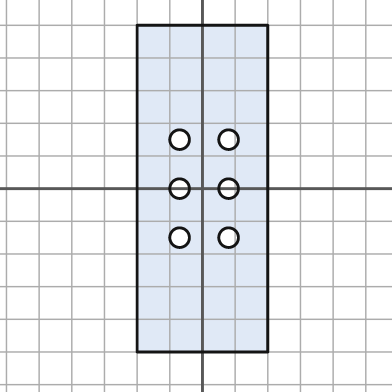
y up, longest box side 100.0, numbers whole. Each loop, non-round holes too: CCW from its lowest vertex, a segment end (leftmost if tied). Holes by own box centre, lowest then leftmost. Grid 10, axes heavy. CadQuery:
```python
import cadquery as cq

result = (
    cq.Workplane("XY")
    .moveTo(-20.0, -50.0)
    .lineTo(20.0, -50.0)
    .lineTo(20.0, 50.0)
    .lineTo(-20.0, 50.0)
    .close()
    .moveTo(-7.0, -15.0)
    .circle(3.0)
    .moveTo(8.0, -15.0)
    .circle(3.0)
    .moveTo(-7.0, 0.0)
    .circle(3.0)
    .moveTo(8.0, 0.0)
    .circle(3.0)
    .moveTo(-7.0, 15.0)
    .circle(3.0)
    .moveTo(8.0, 15.0)
    .circle(3.0)
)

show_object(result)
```